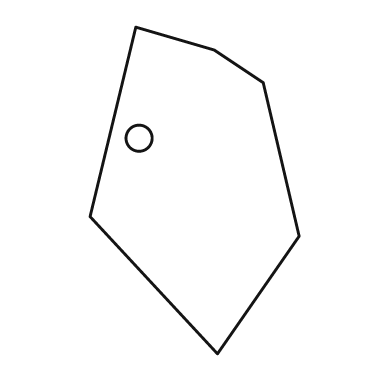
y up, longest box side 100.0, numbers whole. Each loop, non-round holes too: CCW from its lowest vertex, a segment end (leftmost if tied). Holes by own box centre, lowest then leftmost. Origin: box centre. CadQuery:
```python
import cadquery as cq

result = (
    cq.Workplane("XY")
    .moveTo(7.0, -50.0)
    .lineTo(32.0, -14.0)
    .lineTo(21.0, 33.0)
    .lineTo(6.0, 43.0)
    .lineTo(-18.0, 50.0)
    .lineTo(-32.0, -8.0)
    .close()
    .moveTo(-17.0, 16.0)
    .circle(4.0)
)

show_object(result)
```